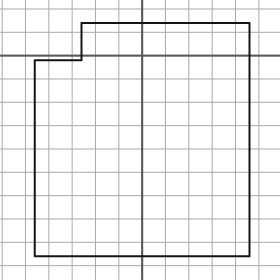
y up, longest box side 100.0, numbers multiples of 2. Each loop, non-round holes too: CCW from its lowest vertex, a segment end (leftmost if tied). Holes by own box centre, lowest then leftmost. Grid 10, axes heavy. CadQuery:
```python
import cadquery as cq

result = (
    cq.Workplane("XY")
    .moveTo(-46.0, -86.0)
    .lineTo(46.0, -86.0)
    .lineTo(46.0, 14.0)
    .lineTo(-26.0, 14.0)
    .lineTo(-26.0, -2.0)
    .lineTo(-46.0, -2.0)
    .close()
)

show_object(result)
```